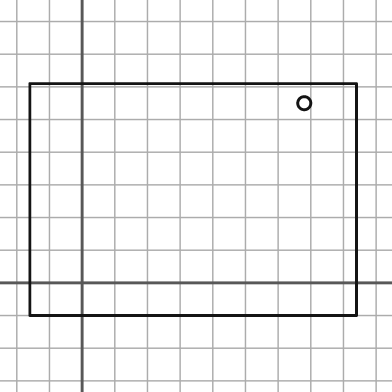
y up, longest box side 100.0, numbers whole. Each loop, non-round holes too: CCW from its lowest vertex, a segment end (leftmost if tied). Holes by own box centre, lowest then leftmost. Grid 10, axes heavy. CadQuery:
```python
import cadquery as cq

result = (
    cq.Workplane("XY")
    .moveTo(-16.0, -10.0)
    .lineTo(84.0, -10.0)
    .lineTo(84.0, 61.0)
    .lineTo(-16.0, 61.0)
    .close()
    .moveTo(68.0, 55.0)
    .circle(2.0)
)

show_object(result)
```